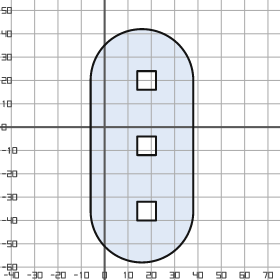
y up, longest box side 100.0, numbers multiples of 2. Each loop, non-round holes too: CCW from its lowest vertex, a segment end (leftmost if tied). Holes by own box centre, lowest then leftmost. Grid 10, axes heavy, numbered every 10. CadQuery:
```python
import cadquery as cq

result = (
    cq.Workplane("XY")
    .moveTo(-6.0, -36.0)
    .threePointArc((16.0, -58.0), (38.0, -36.0))
    .lineTo(38.0, 20.0)
    .threePointArc((16.0, 42.0), (-6.0, 20.0))
    .close()
    .moveTo(14.0, -40.0)
    .lineTo(22.0, -40.0)
    .lineTo(22.0, -32.0)
    .lineTo(14.0, -32.0)
    .close()
    .moveTo(14.0, -12.0)
    .lineTo(22.0, -12.0)
    .lineTo(22.0, -4.0)
    .lineTo(14.0, -4.0)
    .close()
    .moveTo(14.0, 16.0)
    .lineTo(22.0, 16.0)
    .lineTo(22.0, 24.0)
    .lineTo(14.0, 24.0)
    .close()
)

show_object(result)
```